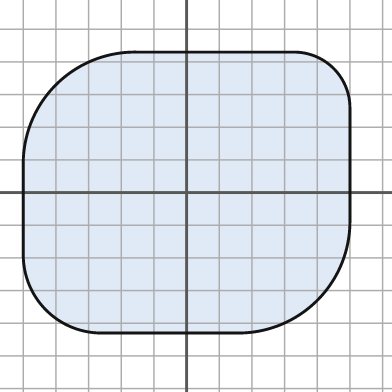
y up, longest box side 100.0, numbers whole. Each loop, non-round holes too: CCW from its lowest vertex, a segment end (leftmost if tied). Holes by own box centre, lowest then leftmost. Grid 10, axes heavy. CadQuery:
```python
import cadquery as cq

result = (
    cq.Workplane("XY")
    .moveTo(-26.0, -43.0)
    .lineTo(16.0, -43.0)
    .threePointArc((40.0, -33.0), (50.0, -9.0))
    .lineTo(50.0, 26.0)
    .threePointArc((45.0, 38.0), (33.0, 43.0))
    .lineTo(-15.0, 43.0)
    .threePointArc((-40.0, 33.0), (-50.0, 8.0))
    .lineTo(-50.0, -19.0)
    .threePointArc((-43.0, -36.0), (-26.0, -43.0))
    .close()
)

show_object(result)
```